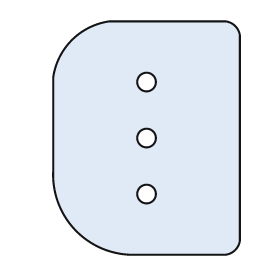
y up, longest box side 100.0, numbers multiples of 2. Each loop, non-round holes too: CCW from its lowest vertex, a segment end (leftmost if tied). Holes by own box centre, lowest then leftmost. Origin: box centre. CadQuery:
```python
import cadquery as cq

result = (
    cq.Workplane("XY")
    .moveTo(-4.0, -50.0)
    .lineTo(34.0, -50.0)
    .threePointArc((38.0, -48.0), (40.0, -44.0))
    .lineTo(40.0, 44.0)
    .threePointArc((38.0, 48.0), (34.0, 50.0))
    .lineTo(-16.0, 50.0)
    .threePointArc((-32.0, 42.0), (-40.0, 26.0))
    .lineTo(-40.0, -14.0)
    .threePointArc((-30.0, -40.0), (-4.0, -50.0))
    .close()
    .moveTo(0.0, -24.0)
    .circle(4.0)
    .moveTo(0.0, 0.0)
    .circle(4.0)
    .moveTo(0.0, 24.0)
    .circle(4.0)
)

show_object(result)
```